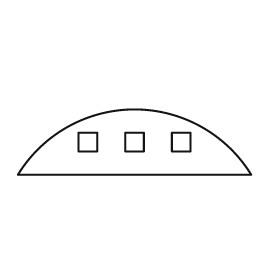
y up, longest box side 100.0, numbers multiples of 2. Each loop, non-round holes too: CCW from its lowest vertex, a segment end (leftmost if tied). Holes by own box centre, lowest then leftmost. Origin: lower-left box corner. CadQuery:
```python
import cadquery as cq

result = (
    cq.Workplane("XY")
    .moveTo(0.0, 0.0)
    .lineTo(100.0, 0.0)
    .threePointArc((50.0, 28.0), (0.0, 0.0))
    .close()
    .moveTo(26.0, 10.0)
    .lineTo(34.0, 10.0)
    .lineTo(34.0, 18.0)
    .lineTo(26.0, 18.0)
    .close()
    .moveTo(46.0, 10.0)
    .lineTo(54.0, 10.0)
    .lineTo(54.0, 18.0)
    .lineTo(46.0, 18.0)
    .close()
    .moveTo(66.0, 10.0)
    .lineTo(74.0, 10.0)
    .lineTo(74.0, 18.0)
    .lineTo(66.0, 18.0)
    .close()
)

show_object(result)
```